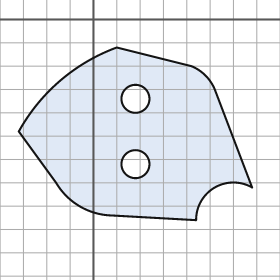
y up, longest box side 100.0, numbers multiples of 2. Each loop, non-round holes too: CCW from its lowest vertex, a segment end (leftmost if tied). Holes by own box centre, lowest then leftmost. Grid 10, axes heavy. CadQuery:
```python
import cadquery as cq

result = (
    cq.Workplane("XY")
    .moveTo(44.0, -86.0)
    .threePointArc((52.0, -72.0), (68.0, -72.0))
    .lineTo(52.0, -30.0)
    .threePointArc((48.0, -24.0), (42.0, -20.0))
    .lineTo(10.0, -12.0)
    .threePointArc((-14.0, -26.0), (-32.0, -48.0))
    .lineTo(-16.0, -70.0)
    .threePointArc((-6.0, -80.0), (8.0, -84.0))
    .close()
    .moveTo(18.0, -62.0)
    .circle(6.0)
    .moveTo(18.0, -34.0)
    .circle(6.0)
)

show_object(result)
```